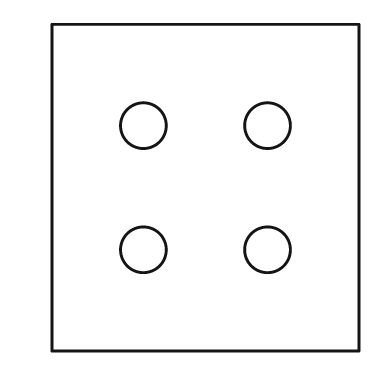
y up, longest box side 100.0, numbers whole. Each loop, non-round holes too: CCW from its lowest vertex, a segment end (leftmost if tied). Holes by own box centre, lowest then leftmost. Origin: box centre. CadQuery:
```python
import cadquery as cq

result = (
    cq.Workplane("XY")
    .moveTo(-47.0, -50.0)
    .lineTo(47.0, -50.0)
    .lineTo(47.0, 50.0)
    .lineTo(-47.0, 50.0)
    .close()
    .moveTo(-19.0, -19.0)
    .circle(7.0)
    .moveTo(19.0, -19.0)
    .circle(7.0)
    .moveTo(-19.0, 19.0)
    .circle(7.0)
    .moveTo(19.0, 19.0)
    .circle(7.0)
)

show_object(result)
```